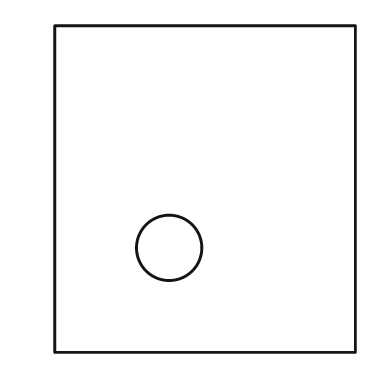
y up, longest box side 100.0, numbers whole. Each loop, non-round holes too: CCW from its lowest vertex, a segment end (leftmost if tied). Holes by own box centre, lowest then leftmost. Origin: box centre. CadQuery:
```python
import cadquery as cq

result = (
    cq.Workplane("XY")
    .moveTo(-46.0, -50.0)
    .lineTo(46.0, -50.0)
    .lineTo(46.0, 50.0)
    .lineTo(-46.0, 50.0)
    .close()
    .moveTo(-11.0, -18.0)
    .circle(10.0)
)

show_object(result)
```